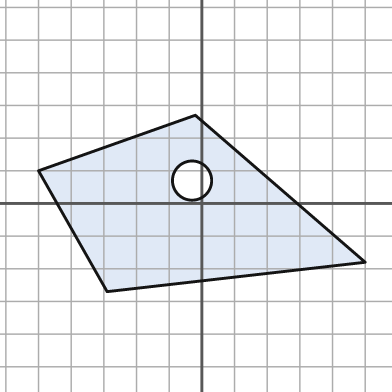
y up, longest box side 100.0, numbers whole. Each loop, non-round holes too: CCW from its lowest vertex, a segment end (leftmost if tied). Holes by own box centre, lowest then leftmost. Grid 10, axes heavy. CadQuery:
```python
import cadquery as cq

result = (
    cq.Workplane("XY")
    .moveTo(-29.0, -27.0)
    .lineTo(50.0, -18.0)
    .lineTo(-2.0, 27.0)
    .lineTo(-50.0, 10.0)
    .close()
    .moveTo(-3.0, 7.0)
    .circle(6.0)
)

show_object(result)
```